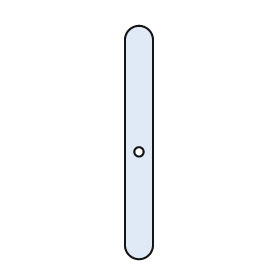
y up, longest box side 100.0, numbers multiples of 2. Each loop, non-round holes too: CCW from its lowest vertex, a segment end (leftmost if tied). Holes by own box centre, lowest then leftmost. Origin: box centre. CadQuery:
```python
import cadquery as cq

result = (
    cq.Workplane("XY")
    .moveTo(-6.0, -44.0)
    .threePointArc((0.0, -50.0), (6.0, -44.0))
    .lineTo(6.0, 44.0)
    .threePointArc((0.0, 50.0), (-6.0, 44.0))
    .close()
    .moveTo(0.0, -4.0)
    .circle(2.0)
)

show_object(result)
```